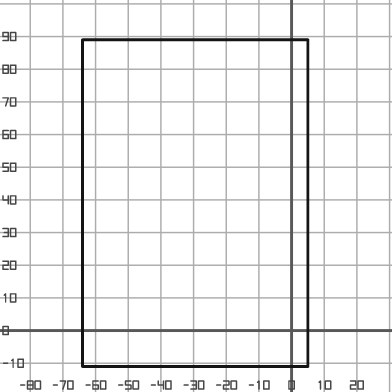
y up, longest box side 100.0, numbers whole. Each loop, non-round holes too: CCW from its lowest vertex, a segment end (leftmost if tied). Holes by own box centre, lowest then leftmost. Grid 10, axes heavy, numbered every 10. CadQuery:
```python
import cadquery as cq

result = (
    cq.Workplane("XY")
    .moveTo(-64.0, -11.0)
    .lineTo(5.0, -11.0)
    .lineTo(5.0, 89.0)
    .lineTo(-64.0, 89.0)
    .close()
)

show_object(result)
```